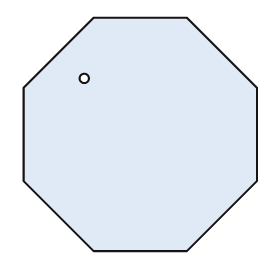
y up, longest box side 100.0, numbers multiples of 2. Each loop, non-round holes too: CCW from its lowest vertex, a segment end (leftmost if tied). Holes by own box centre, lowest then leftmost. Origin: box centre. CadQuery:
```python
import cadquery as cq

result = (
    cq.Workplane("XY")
    .moveTo(-20.0, -50.0)
    .lineTo(20.0, -50.0)
    .lineTo(50.0, -20.0)
    .lineTo(50.0, 20.0)
    .lineTo(20.0, 50.0)
    .lineTo(-20.0, 50.0)
    .lineTo(-50.0, 20.0)
    .lineTo(-50.0, -20.0)
    .close()
    .moveTo(-24.0, 24.0)
    .circle(2.0)
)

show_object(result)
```